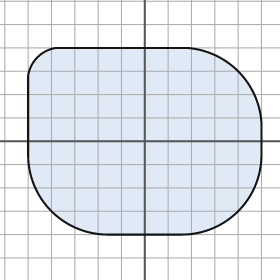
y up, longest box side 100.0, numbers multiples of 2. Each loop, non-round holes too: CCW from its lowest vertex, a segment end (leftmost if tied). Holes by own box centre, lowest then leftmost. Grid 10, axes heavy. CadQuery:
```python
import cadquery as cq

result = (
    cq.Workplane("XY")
    .moveTo(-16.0, -40.0)
    .lineTo(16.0, -40.0)
    .threePointArc((40.0, -30.0), (50.0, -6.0))
    .lineTo(50.0, 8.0)
    .threePointArc((40.0, 30.0), (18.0, 40.0))
    .lineTo(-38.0, 40.0)
    .threePointArc((-46.0, 36.0), (-50.0, 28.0))
    .lineTo(-50.0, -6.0)
    .threePointArc((-40.0, -30.0), (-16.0, -40.0))
    .close()
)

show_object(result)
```